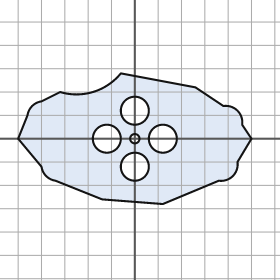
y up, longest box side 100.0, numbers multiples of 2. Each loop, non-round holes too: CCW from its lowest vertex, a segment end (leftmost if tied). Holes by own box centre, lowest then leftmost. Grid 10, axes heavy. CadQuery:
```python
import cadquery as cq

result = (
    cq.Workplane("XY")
    .moveTo(12.0, -28.0)
    .lineTo(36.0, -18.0)
    .threePointArc((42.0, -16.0), (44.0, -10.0))
    .lineTo(50.0, 0.0)
    .lineTo(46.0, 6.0)
    .threePointArc((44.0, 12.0), (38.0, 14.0))
    .lineTo(26.0, 22.0)
    .lineTo(-6.0, 28.0)
    .threePointArc((-18.0, 20.0), (-32.0, 20.0))
    .lineTo(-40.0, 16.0)
    .threePointArc((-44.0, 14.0), (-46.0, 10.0))
    .lineTo(-50.0, 0.0)
    .lineTo(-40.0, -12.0)
    .threePointArc((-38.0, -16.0), (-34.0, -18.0))
    .lineTo(-14.0, -26.0)
    .close()
    .moveTo(0.0, -12.0)
    .circle(6.0)
    .moveTo(-12.0, 0.0)
    .circle(6.0)
    .moveTo(0.0, 0.0)
    .circle(2.0)
    .moveTo(12.0, 0.0)
    .circle(6.0)
    .moveTo(0.0, 12.0)
    .circle(6.0)
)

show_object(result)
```